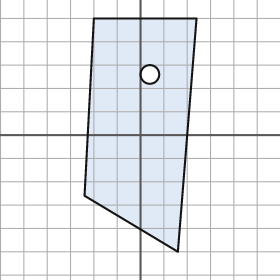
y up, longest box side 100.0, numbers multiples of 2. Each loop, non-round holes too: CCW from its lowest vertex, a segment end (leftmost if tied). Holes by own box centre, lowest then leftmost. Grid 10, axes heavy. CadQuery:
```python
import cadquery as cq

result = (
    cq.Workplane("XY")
    .moveTo(16.0, -50.0)
    .lineTo(24.0, 50.0)
    .lineTo(-20.0, 50.0)
    .lineTo(-24.0, -26.0)
    .close()
    .moveTo(4.0, 26.0)
    .circle(4.0)
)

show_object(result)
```